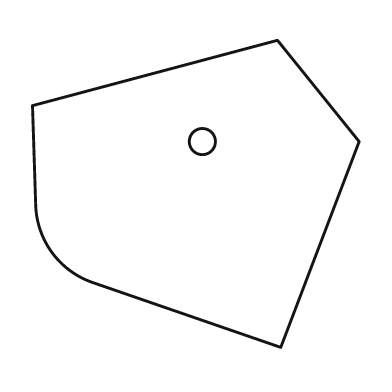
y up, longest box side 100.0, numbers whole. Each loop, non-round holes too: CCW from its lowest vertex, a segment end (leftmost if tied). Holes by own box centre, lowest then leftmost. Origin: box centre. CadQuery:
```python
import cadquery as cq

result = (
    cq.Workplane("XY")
    .moveTo(26.0, -47.0)
    .lineTo(50.0, 16.0)
    .lineTo(25.0, 47.0)
    .lineTo(-50.0, 27.0)
    .lineTo(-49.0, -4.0)
    .threePointArc((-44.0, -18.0), (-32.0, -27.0))
    .close()
    .moveTo(2.0, 16.0)
    .circle(4.0)
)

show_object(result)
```